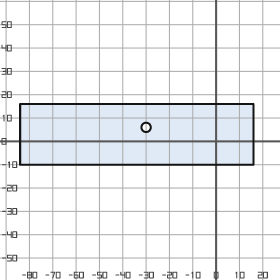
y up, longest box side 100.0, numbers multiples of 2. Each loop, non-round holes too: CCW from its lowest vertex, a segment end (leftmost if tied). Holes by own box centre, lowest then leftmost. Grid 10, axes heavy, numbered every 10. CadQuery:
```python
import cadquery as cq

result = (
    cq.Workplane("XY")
    .moveTo(-84.0, -10.0)
    .lineTo(16.0, -10.0)
    .lineTo(16.0, 16.0)
    .lineTo(-84.0, 16.0)
    .close()
    .moveTo(-30.0, 6.0)
    .circle(2.0)
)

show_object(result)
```